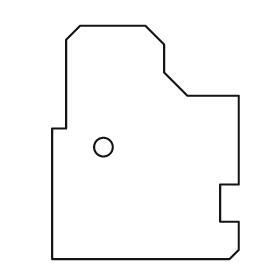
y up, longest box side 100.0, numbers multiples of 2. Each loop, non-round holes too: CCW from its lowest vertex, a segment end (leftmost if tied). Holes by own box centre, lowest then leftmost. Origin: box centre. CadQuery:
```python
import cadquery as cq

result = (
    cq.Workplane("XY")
    .moveTo(-40.0, -50.0)
    .lineTo(36.0, -50.0)
    .lineTo(40.0, -46.0)
    .lineTo(40.0, -34.0)
    .lineTo(32.0, -34.0)
    .lineTo(32.0, -18.0)
    .lineTo(40.0, -18.0)
    .lineTo(40.0, 20.0)
    .lineTo(18.0, 20.0)
    .lineTo(8.0, 30.0)
    .lineTo(8.0, 42.0)
    .lineTo(0.0, 50.0)
    .lineTo(-28.0, 50.0)
    .lineTo(-34.0, 44.0)
    .lineTo(-34.0, 6.0)
    .lineTo(-40.0, 6.0)
    .close()
    .moveTo(-18.0, -2.0)
    .circle(4.0)
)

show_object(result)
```